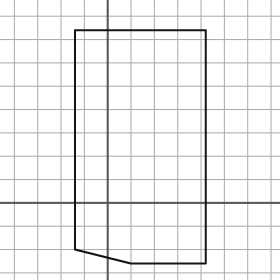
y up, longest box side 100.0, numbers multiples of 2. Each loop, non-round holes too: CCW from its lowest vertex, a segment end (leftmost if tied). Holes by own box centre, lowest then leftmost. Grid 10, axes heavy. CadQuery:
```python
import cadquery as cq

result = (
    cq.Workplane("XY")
    .moveTo(10.0, -26.0)
    .lineTo(42.0, -26.0)
    .lineTo(42.0, 74.0)
    .lineTo(-14.0, 74.0)
    .lineTo(-14.0, -20.0)
    .close()
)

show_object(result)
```